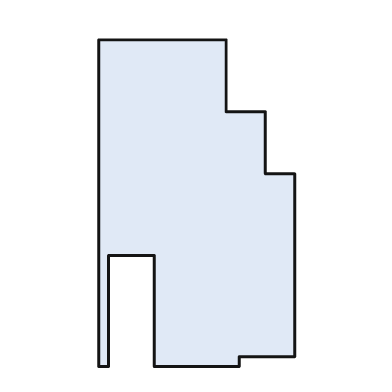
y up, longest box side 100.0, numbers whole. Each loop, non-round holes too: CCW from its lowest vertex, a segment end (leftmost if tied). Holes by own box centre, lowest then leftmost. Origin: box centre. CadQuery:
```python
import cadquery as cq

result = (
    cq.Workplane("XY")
    .moveTo(-30.0, -50.0)
    .lineTo(-27.0, -50.0)
    .lineTo(-27.0, -16.0)
    .lineTo(-13.0, -16.0)
    .lineTo(-13.0, -50.0)
    .lineTo(13.0, -50.0)
    .lineTo(13.0, -47.0)
    .lineTo(30.0, -47.0)
    .lineTo(30.0, 9.0)
    .lineTo(21.0, 9.0)
    .lineTo(21.0, 28.0)
    .lineTo(9.0, 28.0)
    .lineTo(9.0, 50.0)
    .lineTo(-30.0, 50.0)
    .close()
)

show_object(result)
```